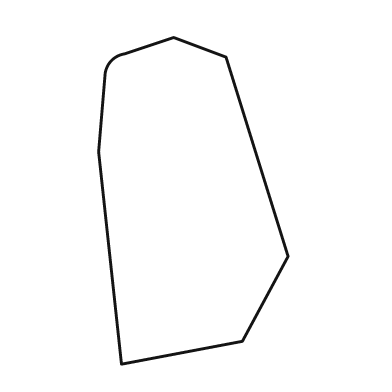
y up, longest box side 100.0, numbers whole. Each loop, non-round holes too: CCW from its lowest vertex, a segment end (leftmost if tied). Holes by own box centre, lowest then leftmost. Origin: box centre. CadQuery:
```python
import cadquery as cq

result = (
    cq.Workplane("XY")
    .moveTo(-22.0, -50.0)
    .lineTo(15.0, -43.0)
    .lineTo(29.0, -17.0)
    .lineTo(10.0, 44.0)
    .lineTo(-6.0, 50.0)
    .lineTo(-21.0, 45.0)
    .threePointArc((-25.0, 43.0), (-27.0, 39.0))
    .lineTo(-29.0, 15.0)
    .close()
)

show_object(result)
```